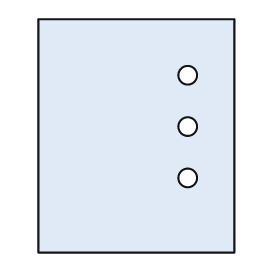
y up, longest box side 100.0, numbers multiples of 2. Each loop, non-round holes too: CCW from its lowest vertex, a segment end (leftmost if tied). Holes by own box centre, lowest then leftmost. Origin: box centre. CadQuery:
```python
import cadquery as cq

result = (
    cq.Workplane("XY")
    .moveTo(-42.0, -50.0)
    .lineTo(42.0, -50.0)
    .lineTo(42.0, 50.0)
    .lineTo(-42.0, 50.0)
    .close()
    .moveTo(22.0, -18.0)
    .circle(4.0)
    .moveTo(22.0, 4.0)
    .circle(4.0)
    .moveTo(22.0, 26.0)
    .circle(4.0)
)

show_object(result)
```